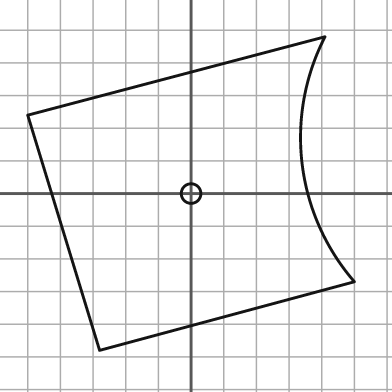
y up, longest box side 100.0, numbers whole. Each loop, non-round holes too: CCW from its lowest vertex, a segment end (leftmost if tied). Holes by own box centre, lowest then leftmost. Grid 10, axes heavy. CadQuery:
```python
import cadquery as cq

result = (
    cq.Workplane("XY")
    .moveTo(-28.0, -48.0)
    .lineTo(50.0, -27.0)
    .threePointArc((34.0, 9.0), (41.0, 48.0))
    .lineTo(-50.0, 24.0)
    .close()
    .moveTo(0.0, 0.0)
    .circle(3.0)
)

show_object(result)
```